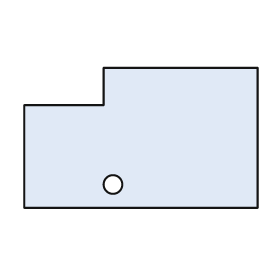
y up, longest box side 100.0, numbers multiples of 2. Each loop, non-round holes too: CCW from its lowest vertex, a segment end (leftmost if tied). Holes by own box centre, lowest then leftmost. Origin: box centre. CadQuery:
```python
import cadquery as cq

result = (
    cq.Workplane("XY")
    .moveTo(-50.0, -30.0)
    .lineTo(50.0, -30.0)
    .lineTo(50.0, 30.0)
    .lineTo(-16.0, 30.0)
    .lineTo(-16.0, 14.0)
    .lineTo(-50.0, 14.0)
    .close()
    .moveTo(-12.0, -20.0)
    .circle(4.0)
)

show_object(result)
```